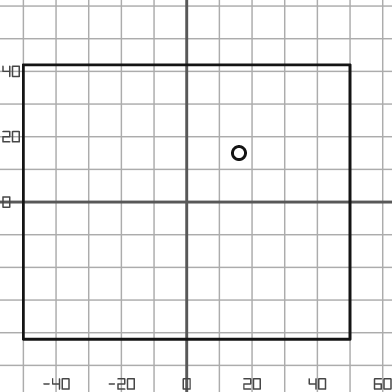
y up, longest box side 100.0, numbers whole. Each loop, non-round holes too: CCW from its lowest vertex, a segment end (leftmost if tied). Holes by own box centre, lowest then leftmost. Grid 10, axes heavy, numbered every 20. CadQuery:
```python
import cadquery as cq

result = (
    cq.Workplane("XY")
    .moveTo(-50.0, -42.0)
    .lineTo(50.0, -42.0)
    .lineTo(50.0, 42.0)
    .lineTo(-50.0, 42.0)
    .close()
    .moveTo(16.0, 15.0)
    .circle(2.0)
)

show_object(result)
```